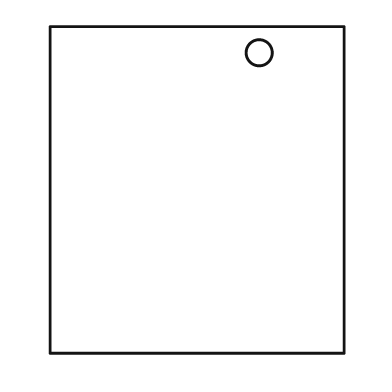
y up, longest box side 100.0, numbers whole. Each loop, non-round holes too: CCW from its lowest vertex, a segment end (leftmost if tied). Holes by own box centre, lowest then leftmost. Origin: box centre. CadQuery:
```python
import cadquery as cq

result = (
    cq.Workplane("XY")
    .moveTo(-45.0, -50.0)
    .lineTo(45.0, -50.0)
    .lineTo(45.0, 50.0)
    .lineTo(-45.0, 50.0)
    .close()
    .moveTo(19.0, 42.0)
    .circle(4.0)
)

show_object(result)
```